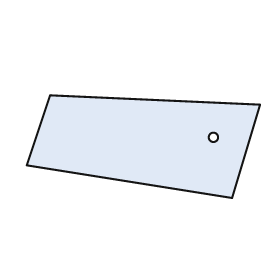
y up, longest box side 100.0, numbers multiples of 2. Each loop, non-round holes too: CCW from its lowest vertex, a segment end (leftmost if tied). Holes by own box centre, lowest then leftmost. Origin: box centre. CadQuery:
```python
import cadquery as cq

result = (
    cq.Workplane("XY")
    .moveTo(38.0, -22.0)
    .lineTo(50.0, 18.0)
    .lineTo(-40.0, 22.0)
    .lineTo(-50.0, -8.0)
    .close()
    .moveTo(30.0, 4.0)
    .circle(2.0)
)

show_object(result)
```